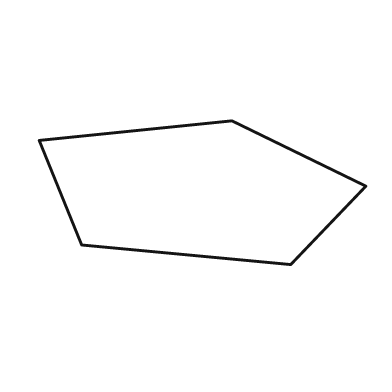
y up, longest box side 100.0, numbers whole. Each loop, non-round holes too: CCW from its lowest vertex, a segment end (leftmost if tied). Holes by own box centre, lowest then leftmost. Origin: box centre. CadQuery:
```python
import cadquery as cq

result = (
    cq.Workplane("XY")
    .moveTo(27.0, -22.0)
    .lineTo(50.0, 2.0)
    .lineTo(9.0, 22.0)
    .lineTo(-50.0, 16.0)
    .lineTo(-37.0, -16.0)
    .close()
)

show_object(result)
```